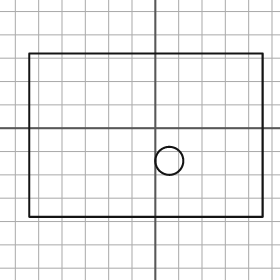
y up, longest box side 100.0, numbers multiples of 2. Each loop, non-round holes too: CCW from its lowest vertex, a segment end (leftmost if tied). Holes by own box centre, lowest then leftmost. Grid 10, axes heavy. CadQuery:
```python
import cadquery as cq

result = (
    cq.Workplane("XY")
    .moveTo(-54.0, -38.0)
    .lineTo(46.0, -38.0)
    .lineTo(46.0, 32.0)
    .lineTo(-54.0, 32.0)
    .close()
    .moveTo(6.0, -14.0)
    .circle(6.0)
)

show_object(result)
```